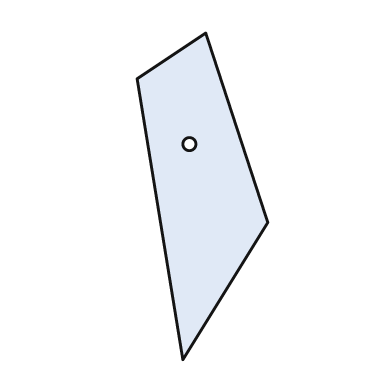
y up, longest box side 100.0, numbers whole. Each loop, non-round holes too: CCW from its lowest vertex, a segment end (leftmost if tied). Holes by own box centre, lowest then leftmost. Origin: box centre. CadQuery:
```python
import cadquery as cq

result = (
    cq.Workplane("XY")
    .moveTo(-6.0, -50.0)
    .lineTo(20.0, -8.0)
    .lineTo(1.0, 50.0)
    .lineTo(-20.0, 36.0)
    .close()
    .moveTo(-4.0, 16.0)
    .circle(2.0)
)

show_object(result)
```